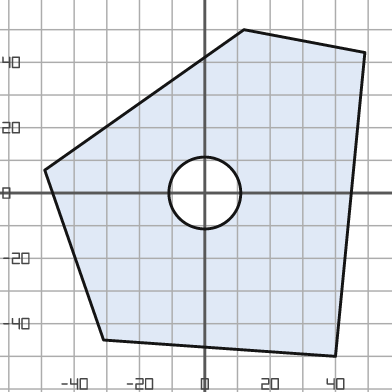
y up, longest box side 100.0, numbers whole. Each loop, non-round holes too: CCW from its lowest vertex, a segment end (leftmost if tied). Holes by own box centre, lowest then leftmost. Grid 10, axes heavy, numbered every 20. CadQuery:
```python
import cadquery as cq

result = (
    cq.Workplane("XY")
    .moveTo(40.0, -50.0)
    .lineTo(49.0, 43.0)
    .lineTo(12.0, 50.0)
    .lineTo(-49.0, 7.0)
    .lineTo(-31.0, -45.0)
    .close()
    .moveTo(0.0, 0.0)
    .circle(11.0)
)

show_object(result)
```